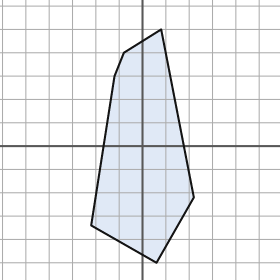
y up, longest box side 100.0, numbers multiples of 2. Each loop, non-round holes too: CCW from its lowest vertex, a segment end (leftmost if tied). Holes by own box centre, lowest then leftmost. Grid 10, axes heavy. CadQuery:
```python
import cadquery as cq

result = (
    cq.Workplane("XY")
    .moveTo(6.0, -50.0)
    .lineTo(22.0, -22.0)
    .lineTo(8.0, 50.0)
    .lineTo(-8.0, 40.0)
    .lineTo(-12.0, 30.0)
    .lineTo(-22.0, -34.0)
    .close()
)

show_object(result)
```